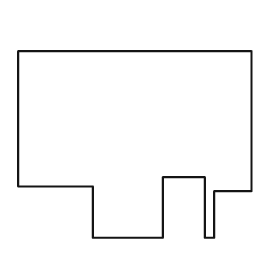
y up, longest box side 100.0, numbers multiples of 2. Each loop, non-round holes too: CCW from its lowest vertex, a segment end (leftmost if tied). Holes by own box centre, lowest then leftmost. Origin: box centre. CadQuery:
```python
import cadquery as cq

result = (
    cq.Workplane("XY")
    .moveTo(-18.0, -40.0)
    .lineTo(12.0, -40.0)
    .lineTo(12.0, -14.0)
    .lineTo(30.0, -14.0)
    .lineTo(30.0, -40.0)
    .lineTo(34.0, -40.0)
    .lineTo(34.0, -20.0)
    .lineTo(50.0, -20.0)
    .lineTo(50.0, 40.0)
    .lineTo(-50.0, 40.0)
    .lineTo(-50.0, -18.0)
    .lineTo(-18.0, -18.0)
    .close()
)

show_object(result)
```